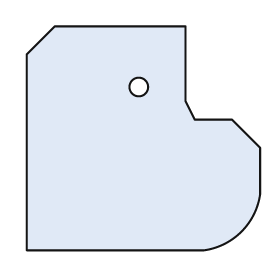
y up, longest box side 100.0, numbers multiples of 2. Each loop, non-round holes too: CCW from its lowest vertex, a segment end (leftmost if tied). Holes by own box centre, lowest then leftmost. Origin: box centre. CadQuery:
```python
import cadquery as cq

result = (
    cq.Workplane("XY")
    .moveTo(-50.0, -48.0)
    .lineTo(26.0, -48.0)
    .threePointArc((42.0, -40.0), (50.0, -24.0))
    .lineTo(50.0, -4.0)
    .lineTo(38.0, 8.0)
    .lineTo(22.0, 8.0)
    .lineTo(18.0, 16.0)
    .lineTo(18.0, 48.0)
    .lineTo(-38.0, 48.0)
    .lineTo(-50.0, 36.0)
    .close()
    .moveTo(-2.0, 22.0)
    .circle(4.0)
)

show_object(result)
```